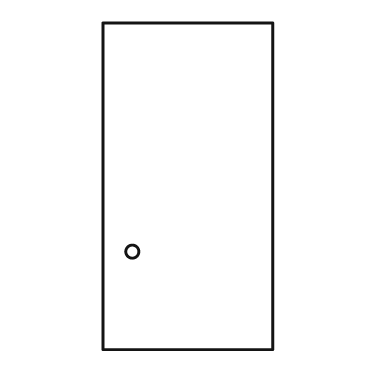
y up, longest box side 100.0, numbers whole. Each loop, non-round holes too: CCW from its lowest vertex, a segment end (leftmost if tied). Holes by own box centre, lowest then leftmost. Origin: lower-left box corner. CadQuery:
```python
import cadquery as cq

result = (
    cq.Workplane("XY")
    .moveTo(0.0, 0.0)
    .lineTo(52.0, 0.0)
    .lineTo(52.0, 100.0)
    .lineTo(0.0, 100.0)
    .close()
    .moveTo(9.0, 30.0)
    .circle(2.0)
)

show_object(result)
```